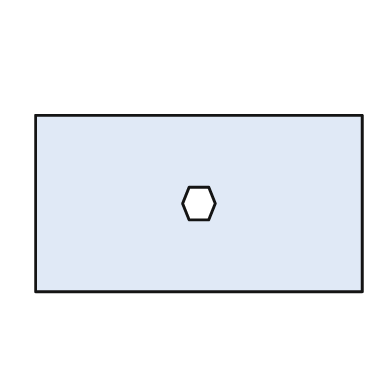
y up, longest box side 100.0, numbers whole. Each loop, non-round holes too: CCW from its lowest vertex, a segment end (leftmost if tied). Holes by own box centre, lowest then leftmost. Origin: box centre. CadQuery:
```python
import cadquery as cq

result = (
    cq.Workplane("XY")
    .moveTo(-50.0, -27.0)
    .lineTo(50.0, -27.0)
    .lineTo(50.0, 27.0)
    .lineTo(-50.0, 27.0)
    .close()
    .moveTo(-3.0, -5.0)
    .lineTo(3.0, -5.0)
    .lineTo(5.0, 0.0)
    .lineTo(3.0, 5.0)
    .lineTo(-3.0, 5.0)
    .lineTo(-5.0, 0.0)
    .close()
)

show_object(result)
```